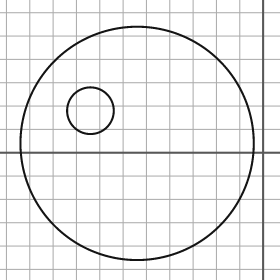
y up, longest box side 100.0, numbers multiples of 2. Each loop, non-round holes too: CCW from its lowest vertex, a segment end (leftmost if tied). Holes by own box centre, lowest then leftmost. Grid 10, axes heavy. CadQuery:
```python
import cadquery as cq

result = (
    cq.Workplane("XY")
    .moveTo(-54.0, 4.0)
    .circle(50.0)
    .moveTo(-74.0, 18.0)
    .circle(10.0)
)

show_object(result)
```